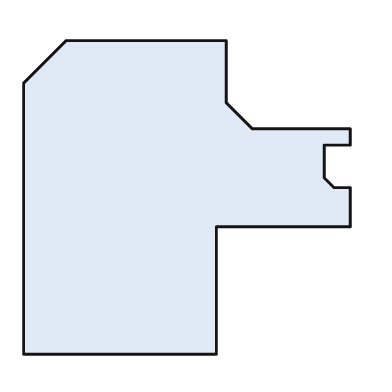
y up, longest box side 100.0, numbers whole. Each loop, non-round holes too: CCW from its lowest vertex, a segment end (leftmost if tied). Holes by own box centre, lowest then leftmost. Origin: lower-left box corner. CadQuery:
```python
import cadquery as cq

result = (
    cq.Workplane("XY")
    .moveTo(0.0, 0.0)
    .lineTo(59.0, 0.0)
    .lineTo(59.0, 39.0)
    .lineTo(100.0, 39.0)
    .lineTo(100.0, 51.0)
    .lineTo(95.0, 51.0)
    .lineTo(92.0, 54.0)
    .lineTo(92.0, 64.0)
    .lineTo(100.0, 64.0)
    .lineTo(100.0, 69.0)
    .lineTo(70.0, 69.0)
    .lineTo(62.0, 77.0)
    .lineTo(62.0, 96.0)
    .lineTo(13.0, 96.0)
    .lineTo(0.0, 83.0)
    .close()
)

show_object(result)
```